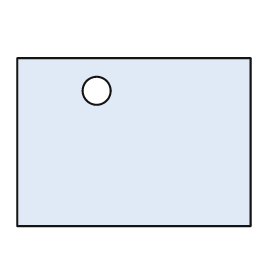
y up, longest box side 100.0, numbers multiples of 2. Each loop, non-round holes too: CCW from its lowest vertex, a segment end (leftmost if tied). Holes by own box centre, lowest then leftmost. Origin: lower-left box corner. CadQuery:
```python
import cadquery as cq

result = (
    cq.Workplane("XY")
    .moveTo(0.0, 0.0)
    .lineTo(100.0, 0.0)
    .lineTo(100.0, 72.0)
    .lineTo(0.0, 72.0)
    .close()
    .moveTo(34.0, 58.0)
    .circle(6.0)
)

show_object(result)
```